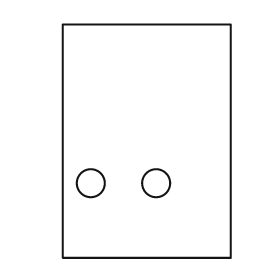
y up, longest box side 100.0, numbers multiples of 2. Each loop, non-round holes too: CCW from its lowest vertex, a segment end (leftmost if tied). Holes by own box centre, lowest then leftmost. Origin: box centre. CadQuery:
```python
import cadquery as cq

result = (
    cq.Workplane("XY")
    .moveTo(-36.0, -50.0)
    .lineTo(36.0, -50.0)
    .lineTo(36.0, 50.0)
    .lineTo(-36.0, 50.0)
    .close()
    .moveTo(-24.0, -18.0)
    .circle(6.0)
    .moveTo(4.0, -18.0)
    .circle(6.0)
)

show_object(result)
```